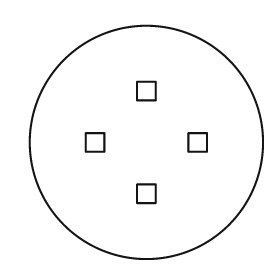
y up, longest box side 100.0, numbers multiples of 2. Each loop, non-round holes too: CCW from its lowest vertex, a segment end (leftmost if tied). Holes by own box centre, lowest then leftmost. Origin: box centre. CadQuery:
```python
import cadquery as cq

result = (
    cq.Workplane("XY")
    .moveTo(0.0, 0.0)
    .circle(50.0)
    .moveTo(-4.0, -26.0)
    .lineTo(4.0, -26.0)
    .lineTo(4.0, -18.0)
    .lineTo(-4.0, -18.0)
    .close()
    .moveTo(-26.0, -4.0)
    .lineTo(-18.0, -4.0)
    .lineTo(-18.0, 4.0)
    .lineTo(-26.0, 4.0)
    .close()
    .moveTo(18.0, -4.0)
    .lineTo(26.0, -4.0)
    .lineTo(26.0, 4.0)
    .lineTo(18.0, 4.0)
    .close()
    .moveTo(-4.0, 18.0)
    .lineTo(4.0, 18.0)
    .lineTo(4.0, 26.0)
    .lineTo(-4.0, 26.0)
    .close()
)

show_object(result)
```